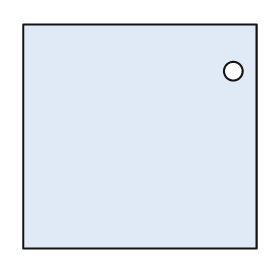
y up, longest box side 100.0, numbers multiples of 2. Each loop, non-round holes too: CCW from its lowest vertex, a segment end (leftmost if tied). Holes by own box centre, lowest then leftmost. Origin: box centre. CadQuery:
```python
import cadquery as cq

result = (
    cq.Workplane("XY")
    .moveTo(-50.0, -48.0)
    .lineTo(50.0, -48.0)
    .lineTo(50.0, 48.0)
    .lineTo(-50.0, 48.0)
    .close()
    .moveTo(40.0, 28.0)
    .circle(4.0)
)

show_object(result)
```